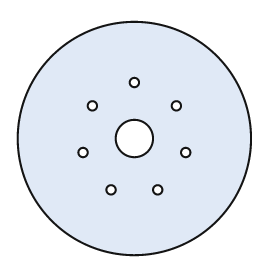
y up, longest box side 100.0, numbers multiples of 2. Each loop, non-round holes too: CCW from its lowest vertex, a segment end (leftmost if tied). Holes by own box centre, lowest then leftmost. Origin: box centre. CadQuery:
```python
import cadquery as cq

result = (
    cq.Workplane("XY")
    .moveTo(0.0, 0.0)
    .circle(50.0)
    .moveTo(-10.0, -22.0)
    .circle(2.0)
    .moveTo(10.0, -22.0)
    .circle(2.0)
    .moveTo(-22.0, -6.0)
    .circle(2.0)
    .moveTo(22.0, -6.0)
    .circle(2.0)
    .moveTo(0.0, 0.0)
    .circle(8.0)
    .moveTo(-18.0, 14.0)
    .circle(2.0)
    .moveTo(18.0, 14.0)
    .circle(2.0)
    .moveTo(0.0, 24.0)
    .circle(2.0)
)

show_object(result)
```